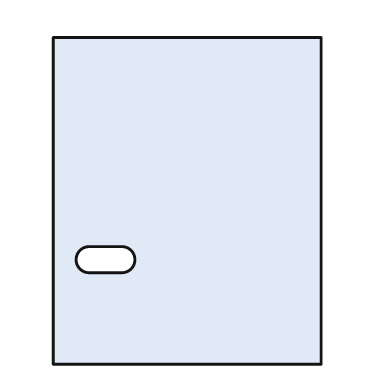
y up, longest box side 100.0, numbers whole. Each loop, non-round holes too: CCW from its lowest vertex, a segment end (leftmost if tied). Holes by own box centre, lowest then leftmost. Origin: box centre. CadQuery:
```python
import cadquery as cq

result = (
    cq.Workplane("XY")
    .moveTo(-41.0, -50.0)
    .lineTo(41.0, -50.0)
    .lineTo(41.0, 50.0)
    .lineTo(-41.0, 50.0)
    .close()
    .moveTo(-30.0, -22.0)
    .lineTo(-20.0, -22.0)
    .threePointArc((-16.0, -18.0), (-20.0, -14.0))
    .lineTo(-30.0, -14.0)
    .threePointArc((-34.0, -18.0), (-30.0, -22.0))
    .close()
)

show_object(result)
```